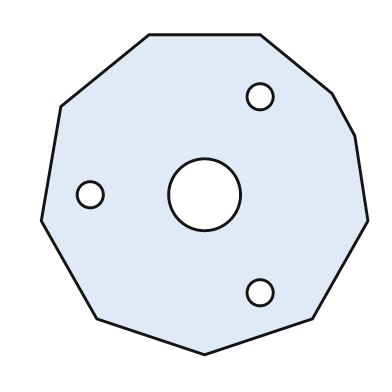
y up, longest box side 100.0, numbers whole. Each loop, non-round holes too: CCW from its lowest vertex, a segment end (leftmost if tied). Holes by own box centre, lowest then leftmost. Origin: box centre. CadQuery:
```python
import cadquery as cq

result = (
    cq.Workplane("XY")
    .moveTo(0.0, -49.0)
    .lineTo(33.0, -38.0)
    .lineTo(50.0, -8.0)
    .lineTo(46.0, 18.0)
    .lineTo(39.0, 31.0)
    .lineTo(17.0, 49.0)
    .lineTo(-17.0, 49.0)
    .lineTo(-44.0, 27.0)
    .lineTo(-50.0, -8.0)
    .lineTo(-33.0, -38.0)
    .close()
    .moveTo(17.0, -30.0)
    .circle(4.0)
    .moveTo(-35.0, 0.0)
    .circle(4.0)
    .moveTo(0.0, 0.0)
    .circle(11.0)
    .moveTo(17.0, 30.0)
    .circle(4.0)
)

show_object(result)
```